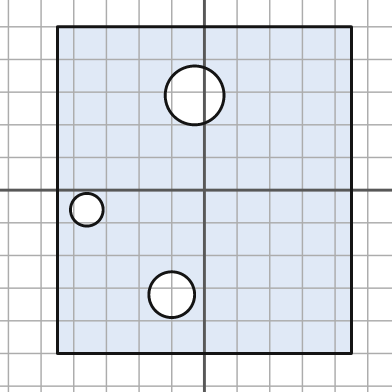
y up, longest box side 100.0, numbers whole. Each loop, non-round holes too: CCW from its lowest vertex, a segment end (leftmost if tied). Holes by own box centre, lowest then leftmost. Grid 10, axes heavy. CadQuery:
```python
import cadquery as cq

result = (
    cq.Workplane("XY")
    .moveTo(-45.0, -50.0)
    .lineTo(45.0, -50.0)
    .lineTo(45.0, 50.0)
    .lineTo(-45.0, 50.0)
    .close()
    .moveTo(-10.0, -32.0)
    .circle(7.0)
    .moveTo(-36.0, -6.0)
    .circle(5.0)
    .moveTo(-3.0, 29.0)
    .circle(9.0)
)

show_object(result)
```